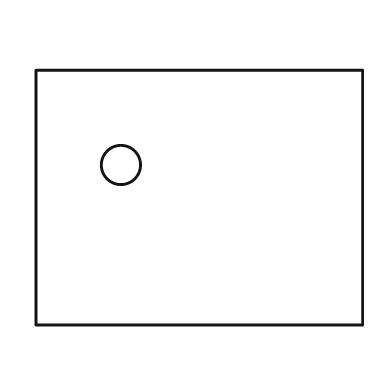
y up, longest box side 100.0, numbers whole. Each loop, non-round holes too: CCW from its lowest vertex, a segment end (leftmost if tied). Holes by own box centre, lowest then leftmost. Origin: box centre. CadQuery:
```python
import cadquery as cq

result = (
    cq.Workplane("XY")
    .moveTo(-50.0, -39.0)
    .lineTo(50.0, -39.0)
    .lineTo(50.0, 39.0)
    .lineTo(-50.0, 39.0)
    .close()
    .moveTo(-24.0, 10.0)
    .circle(6.0)
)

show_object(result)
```